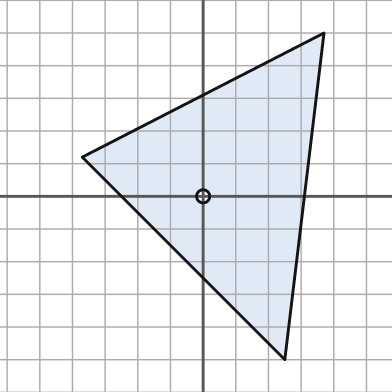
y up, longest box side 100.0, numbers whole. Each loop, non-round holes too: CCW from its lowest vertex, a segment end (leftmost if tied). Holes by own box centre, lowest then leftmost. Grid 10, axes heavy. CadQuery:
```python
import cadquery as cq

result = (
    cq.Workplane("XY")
    .moveTo(25.0, -50.0)
    .lineTo(37.0, 50.0)
    .lineTo(-37.0, 12.0)
    .close()
    .moveTo(0.0, 0.0)
    .circle(2.0)
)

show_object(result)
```